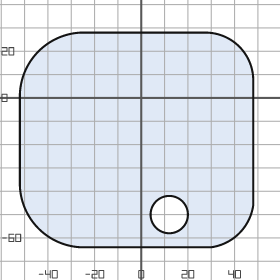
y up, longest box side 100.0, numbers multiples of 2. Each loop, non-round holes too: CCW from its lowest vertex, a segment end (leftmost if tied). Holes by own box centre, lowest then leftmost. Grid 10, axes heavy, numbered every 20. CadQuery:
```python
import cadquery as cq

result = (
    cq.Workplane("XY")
    .moveTo(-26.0, -64.0)
    .lineTo(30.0, -64.0)
    .threePointArc((42.0, -58.0), (48.0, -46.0))
    .lineTo(48.0, 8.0)
    .threePointArc((42.0, 22.0), (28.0, 28.0))
    .lineTo(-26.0, 28.0)
    .threePointArc((-44.0, 20.0), (-52.0, 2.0))
    .lineTo(-52.0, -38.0)
    .threePointArc((-44.0, -56.0), (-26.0, -64.0))
    .close()
    .moveTo(12.0, -50.0)
    .circle(8.0)
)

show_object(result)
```